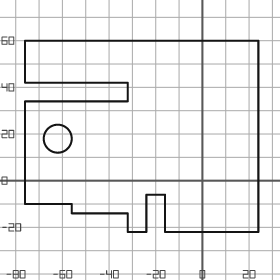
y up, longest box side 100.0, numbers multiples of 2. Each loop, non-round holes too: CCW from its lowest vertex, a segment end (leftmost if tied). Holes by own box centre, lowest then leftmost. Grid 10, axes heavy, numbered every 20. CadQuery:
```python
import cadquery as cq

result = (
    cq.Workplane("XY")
    .moveTo(-32.0, -22.0)
    .lineTo(-24.0, -22.0)
    .lineTo(-24.0, -6.0)
    .lineTo(-16.0, -6.0)
    .lineTo(-16.0, -22.0)
    .lineTo(24.0, -22.0)
    .lineTo(24.0, 60.0)
    .lineTo(-76.0, 60.0)
    .lineTo(-76.0, 42.0)
    .lineTo(-32.0, 42.0)
    .lineTo(-32.0, 34.0)
    .lineTo(-76.0, 34.0)
    .lineTo(-76.0, -10.0)
    .lineTo(-56.0, -10.0)
    .lineTo(-56.0, -14.0)
    .lineTo(-32.0, -14.0)
    .close()
    .moveTo(-62.0, 18.0)
    .circle(6.0)
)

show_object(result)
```